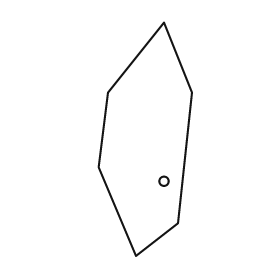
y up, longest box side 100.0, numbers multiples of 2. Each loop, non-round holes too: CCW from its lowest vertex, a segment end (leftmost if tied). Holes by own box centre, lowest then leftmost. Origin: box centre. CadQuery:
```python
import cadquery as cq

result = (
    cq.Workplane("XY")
    .moveTo(-4.0, -50.0)
    .lineTo(14.0, -36.0)
    .lineTo(20.0, 20.0)
    .lineTo(8.0, 50.0)
    .lineTo(-16.0, 20.0)
    .lineTo(-20.0, -12.0)
    .close()
    .moveTo(8.0, -18.0)
    .circle(2.0)
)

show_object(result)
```